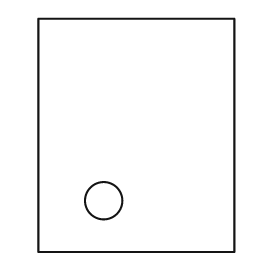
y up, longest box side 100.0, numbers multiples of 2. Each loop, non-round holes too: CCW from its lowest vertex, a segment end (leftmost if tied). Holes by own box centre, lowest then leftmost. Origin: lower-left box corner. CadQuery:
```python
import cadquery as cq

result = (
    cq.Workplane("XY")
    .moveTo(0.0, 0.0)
    .lineTo(84.0, 0.0)
    .lineTo(84.0, 100.0)
    .lineTo(0.0, 100.0)
    .close()
    .moveTo(28.0, 22.0)
    .circle(8.0)
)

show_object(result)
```